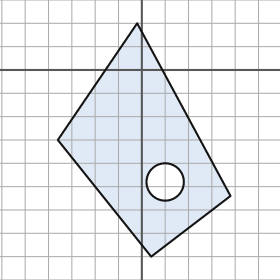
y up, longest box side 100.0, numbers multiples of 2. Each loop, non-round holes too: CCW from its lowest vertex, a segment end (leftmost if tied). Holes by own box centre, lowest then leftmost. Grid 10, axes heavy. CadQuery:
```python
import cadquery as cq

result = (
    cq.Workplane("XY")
    .moveTo(4.0, -80.0)
    .lineTo(38.0, -54.0)
    .lineTo(-2.0, 20.0)
    .lineTo(-36.0, -30.0)
    .close()
    .moveTo(10.0, -48.0)
    .circle(8.0)
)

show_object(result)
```